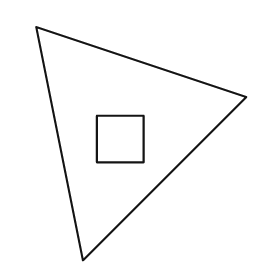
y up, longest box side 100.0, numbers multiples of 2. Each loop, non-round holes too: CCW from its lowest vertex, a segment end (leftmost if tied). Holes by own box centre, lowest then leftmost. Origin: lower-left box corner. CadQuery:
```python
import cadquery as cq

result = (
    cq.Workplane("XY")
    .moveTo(20.0, 0.0)
    .lineTo(90.0, 70.0)
    .lineTo(0.0, 100.0)
    .close()
    .moveTo(26.0, 42.0)
    .lineTo(46.0, 42.0)
    .lineTo(46.0, 62.0)
    .lineTo(26.0, 62.0)
    .close()
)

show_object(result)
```